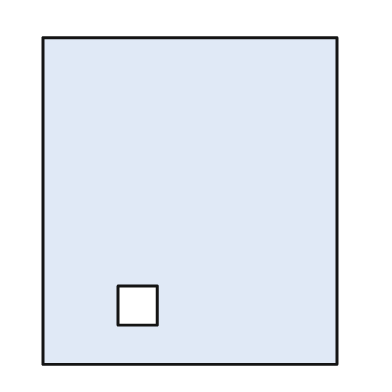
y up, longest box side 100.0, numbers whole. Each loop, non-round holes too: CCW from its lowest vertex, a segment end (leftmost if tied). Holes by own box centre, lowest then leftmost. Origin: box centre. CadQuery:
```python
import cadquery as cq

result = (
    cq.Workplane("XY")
    .moveTo(-45.0, -50.0)
    .lineTo(45.0, -50.0)
    .lineTo(45.0, 50.0)
    .lineTo(-45.0, 50.0)
    .close()
    .moveTo(-22.0, -38.0)
    .lineTo(-10.0, -38.0)
    .lineTo(-10.0, -26.0)
    .lineTo(-22.0, -26.0)
    .close()
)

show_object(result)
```